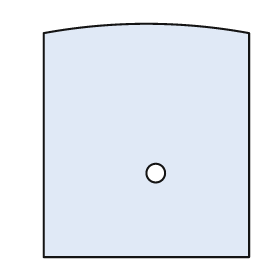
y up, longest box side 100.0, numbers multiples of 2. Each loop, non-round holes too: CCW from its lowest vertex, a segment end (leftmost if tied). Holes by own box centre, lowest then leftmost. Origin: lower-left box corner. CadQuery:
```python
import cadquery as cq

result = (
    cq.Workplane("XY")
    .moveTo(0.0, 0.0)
    .lineTo(88.0, 0.0)
    .lineTo(88.0, 96.0)
    .threePointArc((44.0, 100.0), (0.0, 96.0))
    .close()
    .moveTo(48.0, 36.0)
    .circle(4.0)
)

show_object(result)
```